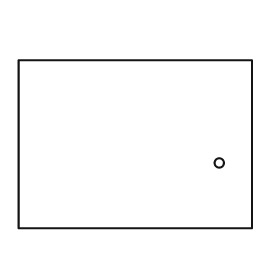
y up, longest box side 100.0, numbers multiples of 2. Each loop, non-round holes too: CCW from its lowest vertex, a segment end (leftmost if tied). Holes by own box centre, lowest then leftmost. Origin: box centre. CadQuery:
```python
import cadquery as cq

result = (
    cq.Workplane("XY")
    .moveTo(-50.0, -36.0)
    .lineTo(50.0, -36.0)
    .lineTo(50.0, 36.0)
    .lineTo(-50.0, 36.0)
    .close()
    .moveTo(36.0, -8.0)
    .circle(2.0)
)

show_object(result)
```